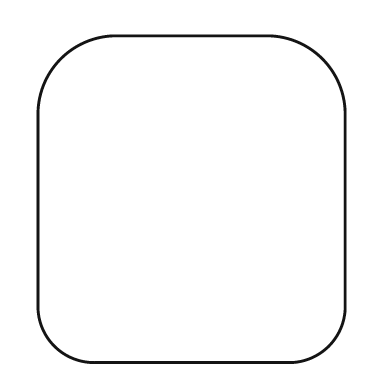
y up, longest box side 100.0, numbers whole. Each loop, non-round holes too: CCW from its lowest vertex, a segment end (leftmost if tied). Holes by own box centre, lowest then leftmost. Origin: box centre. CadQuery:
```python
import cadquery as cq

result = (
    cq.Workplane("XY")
    .moveTo(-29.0, -50.0)
    .lineTo(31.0, -50.0)
    .threePointArc((42.0, -45.0), (47.0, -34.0))
    .lineTo(47.0, 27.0)
    .threePointArc((40.0, 43.0), (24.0, 50.0))
    .lineTo(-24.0, 50.0)
    .threePointArc((-40.0, 43.0), (-47.0, 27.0))
    .lineTo(-47.0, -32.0)
    .threePointArc((-42.0, -45.0), (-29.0, -50.0))
    .close()
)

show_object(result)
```